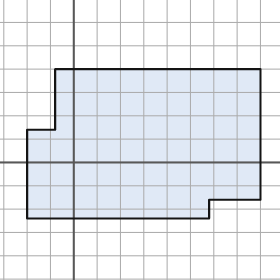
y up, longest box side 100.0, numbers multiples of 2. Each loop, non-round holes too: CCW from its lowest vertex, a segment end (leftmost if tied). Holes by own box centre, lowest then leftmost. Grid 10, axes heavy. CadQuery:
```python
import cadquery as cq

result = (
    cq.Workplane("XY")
    .moveTo(-20.0, -24.0)
    .lineTo(58.0, -24.0)
    .lineTo(58.0, -16.0)
    .lineTo(80.0, -16.0)
    .lineTo(80.0, 40.0)
    .lineTo(-8.0, 40.0)
    .lineTo(-8.0, 14.0)
    .lineTo(-20.0, 14.0)
    .close()
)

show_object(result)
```